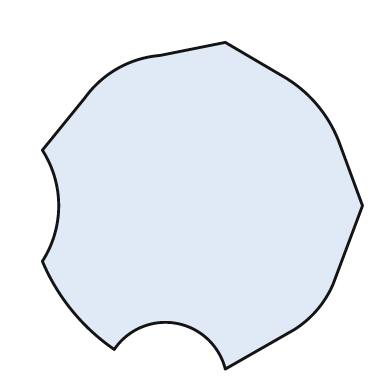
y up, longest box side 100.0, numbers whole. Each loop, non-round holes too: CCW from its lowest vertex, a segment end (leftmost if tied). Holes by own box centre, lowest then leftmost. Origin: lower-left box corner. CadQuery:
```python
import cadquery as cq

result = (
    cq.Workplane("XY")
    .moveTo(56.0, 0.0)
    .lineTo(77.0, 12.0)
    .threePointArc((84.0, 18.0), (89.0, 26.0))
    .lineTo(98.0, 50.0)
    .lineTo(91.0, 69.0)
    .threePointArc((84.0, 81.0), (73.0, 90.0))
    .lineTo(56.0, 100.0)
    .lineTo(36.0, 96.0)
    .threePointArc((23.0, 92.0), (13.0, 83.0))
    .lineTo(0.0, 67.0)
    .threePointArc((5.0, 50.0), (0.0, 33.0))
    .threePointArc((9.0, 18.0), (22.0, 6.0))
    .threePointArc((41.0, 14.0), (56.0, 0.0))
    .close()
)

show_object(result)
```